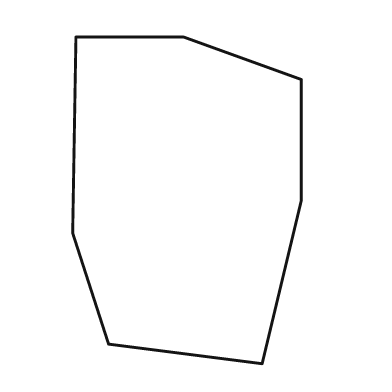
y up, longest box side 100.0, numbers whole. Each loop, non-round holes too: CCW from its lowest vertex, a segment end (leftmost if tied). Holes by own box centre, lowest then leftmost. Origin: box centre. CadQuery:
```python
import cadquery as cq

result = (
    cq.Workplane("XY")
    .moveTo(23.0, -50.0)
    .lineTo(35.0, 0.0)
    .lineTo(35.0, 37.0)
    .lineTo(-1.0, 50.0)
    .lineTo(-34.0, 50.0)
    .lineTo(-35.0, -10.0)
    .lineTo(-24.0, -44.0)
    .close()
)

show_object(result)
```